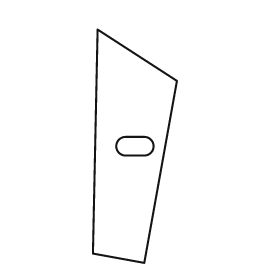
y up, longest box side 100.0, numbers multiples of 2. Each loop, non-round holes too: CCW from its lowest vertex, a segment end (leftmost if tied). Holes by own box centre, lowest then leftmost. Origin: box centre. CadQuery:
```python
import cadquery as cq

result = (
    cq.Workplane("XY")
    .moveTo(4.0, -50.0)
    .lineTo(18.0, 28.0)
    .lineTo(-16.0, 50.0)
    .lineTo(-18.0, -46.0)
    .close()
    .moveTo(-4.0, -4.0)
    .lineTo(4.0, -4.0)
    .threePointArc((8.0, 0.0), (4.0, 4.0))
    .lineTo(-4.0, 4.0)
    .threePointArc((-8.0, 0.0), (-4.0, -4.0))
    .close()
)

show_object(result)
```